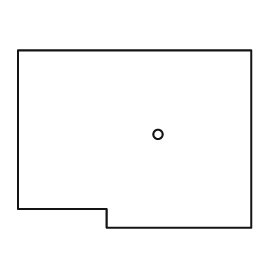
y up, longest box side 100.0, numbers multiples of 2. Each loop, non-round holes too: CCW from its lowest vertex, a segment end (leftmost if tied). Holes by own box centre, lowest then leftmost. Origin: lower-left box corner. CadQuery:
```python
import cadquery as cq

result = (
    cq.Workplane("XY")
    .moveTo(38.0, 0.0)
    .lineTo(100.0, 0.0)
    .lineTo(100.0, 76.0)
    .lineTo(0.0, 76.0)
    .lineTo(0.0, 8.0)
    .lineTo(38.0, 8.0)
    .close()
    .moveTo(60.0, 40.0)
    .circle(2.0)
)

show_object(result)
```